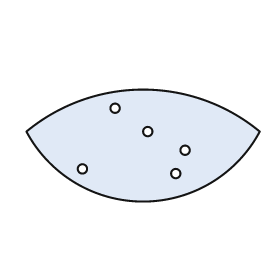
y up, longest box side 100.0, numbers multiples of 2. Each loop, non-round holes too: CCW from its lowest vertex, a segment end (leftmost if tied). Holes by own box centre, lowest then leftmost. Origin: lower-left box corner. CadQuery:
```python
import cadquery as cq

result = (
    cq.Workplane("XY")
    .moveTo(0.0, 30.0)
    .threePointArc((50.0, 0.0), (100.0, 30.0))
    .threePointArc((50.0, 48.0), (0.0, 30.0))
    .close()
    .moveTo(64.0, 12.0)
    .circle(2.0)
    .moveTo(24.0, 14.0)
    .circle(2.0)
    .moveTo(68.0, 22.0)
    .circle(2.0)
    .moveTo(52.0, 30.0)
    .circle(2.0)
    .moveTo(38.0, 40.0)
    .circle(2.0)
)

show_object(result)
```